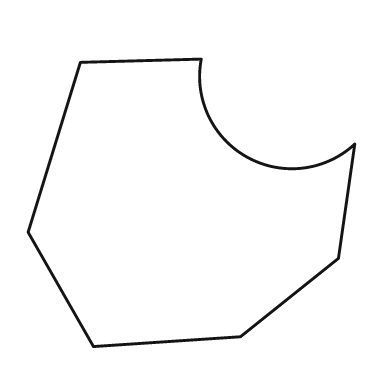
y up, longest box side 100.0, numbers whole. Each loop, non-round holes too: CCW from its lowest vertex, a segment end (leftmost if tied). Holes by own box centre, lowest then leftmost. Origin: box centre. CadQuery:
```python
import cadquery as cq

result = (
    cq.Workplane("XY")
    .moveTo(-30.0, -44.0)
    .lineTo(15.0, -41.0)
    .lineTo(45.0, -17.0)
    .lineTo(50.0, 18.0)
    .threePointArc((17.0, 14.0), (3.0, 44.0))
    .lineTo(-34.0, 43.0)
    .lineTo(-50.0, -9.0)
    .close()
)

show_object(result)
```